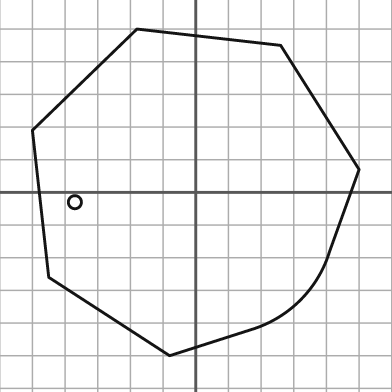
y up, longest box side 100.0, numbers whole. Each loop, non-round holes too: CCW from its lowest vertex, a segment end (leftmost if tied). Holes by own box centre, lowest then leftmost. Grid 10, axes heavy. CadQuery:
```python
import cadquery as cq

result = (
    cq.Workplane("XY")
    .moveTo(-8.0, -50.0)
    .lineTo(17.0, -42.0)
    .threePointArc((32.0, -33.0), (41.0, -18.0))
    .lineTo(50.0, 7.0)
    .lineTo(26.0, 45.0)
    .lineTo(-18.0, 50.0)
    .lineTo(-50.0, 19.0)
    .lineTo(-45.0, -26.0)
    .close()
    .moveTo(-37.0, -3.0)
    .circle(2.0)
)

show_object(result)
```